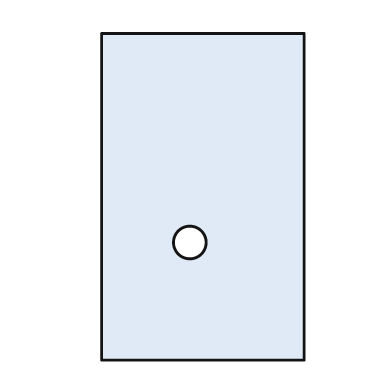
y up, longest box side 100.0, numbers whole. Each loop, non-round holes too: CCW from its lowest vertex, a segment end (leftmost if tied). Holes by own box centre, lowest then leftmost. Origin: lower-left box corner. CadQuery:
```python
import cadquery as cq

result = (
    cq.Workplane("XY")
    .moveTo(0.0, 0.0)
    .lineTo(62.0, 0.0)
    .lineTo(62.0, 100.0)
    .lineTo(0.0, 100.0)
    .close()
    .moveTo(27.0, 36.0)
    .circle(5.0)
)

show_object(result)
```